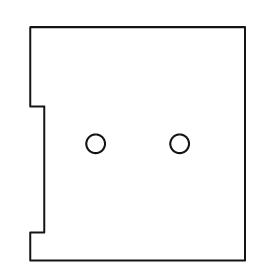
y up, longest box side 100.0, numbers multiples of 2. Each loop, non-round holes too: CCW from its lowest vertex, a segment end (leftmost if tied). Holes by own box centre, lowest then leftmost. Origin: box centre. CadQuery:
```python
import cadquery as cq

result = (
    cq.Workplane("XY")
    .moveTo(-46.0, -50.0)
    .lineTo(46.0, -50.0)
    .lineTo(46.0, 50.0)
    .lineTo(-46.0, 50.0)
    .lineTo(-46.0, 16.0)
    .lineTo(-40.0, 16.0)
    .lineTo(-40.0, -38.0)
    .lineTo(-46.0, -38.0)
    .close()
    .moveTo(-18.0, 0.0)
    .circle(4.0)
    .moveTo(18.0, 0.0)
    .circle(4.0)
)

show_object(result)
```